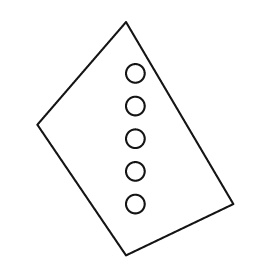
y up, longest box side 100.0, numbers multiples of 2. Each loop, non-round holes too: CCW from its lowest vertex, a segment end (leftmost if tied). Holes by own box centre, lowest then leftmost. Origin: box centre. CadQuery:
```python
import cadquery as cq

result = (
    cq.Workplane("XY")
    .moveTo(-4.0, -50.0)
    .lineTo(42.0, -28.0)
    .lineTo(-4.0, 50.0)
    .lineTo(-42.0, 6.0)
    .close()
    .moveTo(0.0, -28.0)
    .circle(4.0)
    .moveTo(0.0, -14.0)
    .circle(4.0)
    .moveTo(0.0, 0.0)
    .circle(4.0)
    .moveTo(0.0, 14.0)
    .circle(4.0)
    .moveTo(0.0, 28.0)
    .circle(4.0)
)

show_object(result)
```